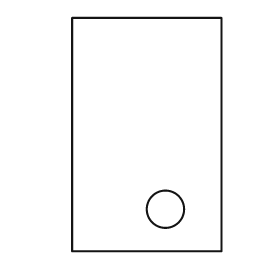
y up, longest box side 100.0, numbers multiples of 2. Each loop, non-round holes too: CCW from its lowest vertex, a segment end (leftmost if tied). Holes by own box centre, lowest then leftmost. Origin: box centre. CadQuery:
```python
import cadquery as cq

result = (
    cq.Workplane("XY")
    .moveTo(-32.0, -50.0)
    .lineTo(32.0, -50.0)
    .lineTo(32.0, 50.0)
    .lineTo(-32.0, 50.0)
    .close()
    .moveTo(8.0, -32.0)
    .circle(8.0)
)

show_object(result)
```